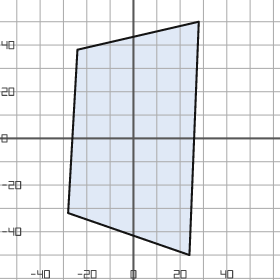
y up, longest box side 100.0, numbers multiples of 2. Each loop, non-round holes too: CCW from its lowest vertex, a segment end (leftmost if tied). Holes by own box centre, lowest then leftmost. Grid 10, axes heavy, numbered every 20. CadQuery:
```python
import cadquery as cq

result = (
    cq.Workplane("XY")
    .moveTo(24.0, -50.0)
    .lineTo(28.0, 50.0)
    .lineTo(-24.0, 38.0)
    .lineTo(-28.0, -32.0)
    .close()
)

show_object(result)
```